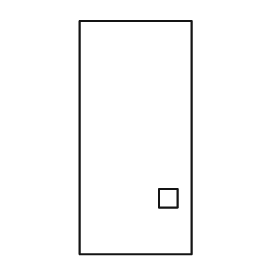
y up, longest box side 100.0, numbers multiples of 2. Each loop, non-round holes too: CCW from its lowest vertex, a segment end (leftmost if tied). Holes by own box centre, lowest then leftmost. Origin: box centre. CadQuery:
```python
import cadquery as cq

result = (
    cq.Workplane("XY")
    .moveTo(-24.0, -50.0)
    .lineTo(24.0, -50.0)
    .lineTo(24.0, 50.0)
    .lineTo(-24.0, 50.0)
    .close()
    .moveTo(10.0, -30.0)
    .lineTo(18.0, -30.0)
    .lineTo(18.0, -22.0)
    .lineTo(10.0, -22.0)
    .close()
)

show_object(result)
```